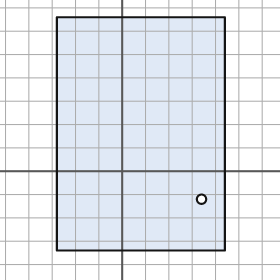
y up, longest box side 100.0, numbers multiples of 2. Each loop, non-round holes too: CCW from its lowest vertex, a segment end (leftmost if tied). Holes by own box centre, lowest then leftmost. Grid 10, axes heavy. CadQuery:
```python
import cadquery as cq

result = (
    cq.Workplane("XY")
    .moveTo(-28.0, -34.0)
    .lineTo(44.0, -34.0)
    .lineTo(44.0, 66.0)
    .lineTo(-28.0, 66.0)
    .close()
    .moveTo(34.0, -12.0)
    .circle(2.0)
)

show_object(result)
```